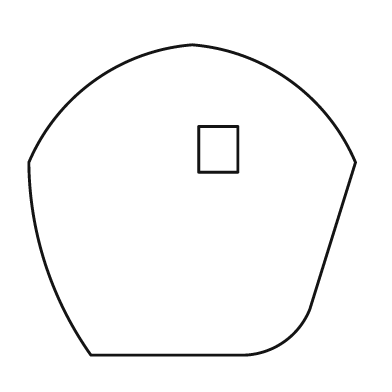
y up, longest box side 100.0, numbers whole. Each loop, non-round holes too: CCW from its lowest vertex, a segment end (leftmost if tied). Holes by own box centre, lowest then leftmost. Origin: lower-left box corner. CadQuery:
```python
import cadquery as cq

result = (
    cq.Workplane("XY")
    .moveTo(19.0, 0.0)
    .lineTo(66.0, 0.0)
    .threePointArc((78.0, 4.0), (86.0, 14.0))
    .lineTo(100.0, 59.0)
    .threePointArc((80.0, 84.0), (50.0, 95.0))
    .threePointArc((20.0, 84.0), (0.0, 59.0))
    .threePointArc((5.0, 28.0), (19.0, 0.0))
    .close()
    .moveTo(52.0, 56.0)
    .lineTo(64.0, 56.0)
    .lineTo(64.0, 70.0)
    .lineTo(52.0, 70.0)
    .close()
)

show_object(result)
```